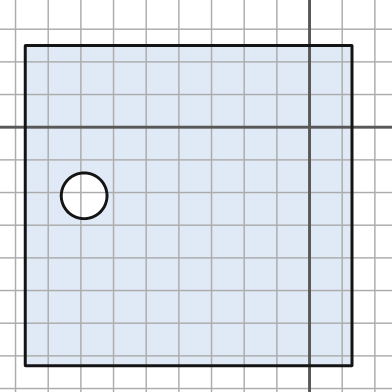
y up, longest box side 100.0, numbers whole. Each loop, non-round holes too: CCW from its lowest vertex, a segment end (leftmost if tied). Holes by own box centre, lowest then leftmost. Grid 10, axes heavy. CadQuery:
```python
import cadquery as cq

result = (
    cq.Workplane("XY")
    .moveTo(-87.0, -73.0)
    .lineTo(13.0, -73.0)
    .lineTo(13.0, 25.0)
    .lineTo(-87.0, 25.0)
    .close()
    .moveTo(-69.0, -21.0)
    .circle(7.0)
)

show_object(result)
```